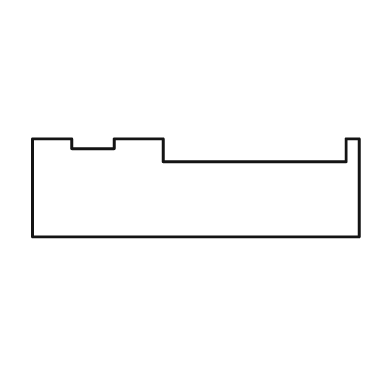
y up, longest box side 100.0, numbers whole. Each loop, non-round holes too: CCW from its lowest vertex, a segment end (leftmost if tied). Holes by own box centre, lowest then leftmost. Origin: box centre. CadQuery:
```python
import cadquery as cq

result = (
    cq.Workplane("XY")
    .moveTo(-50.0, -15.0)
    .lineTo(50.0, -15.0)
    .lineTo(50.0, 15.0)
    .lineTo(46.0, 15.0)
    .lineTo(46.0, 8.0)
    .lineTo(-10.0, 8.0)
    .lineTo(-10.0, 15.0)
    .lineTo(-25.0, 15.0)
    .lineTo(-25.0, 12.0)
    .lineTo(-38.0, 12.0)
    .lineTo(-38.0, 15.0)
    .lineTo(-50.0, 15.0)
    .close()
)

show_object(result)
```